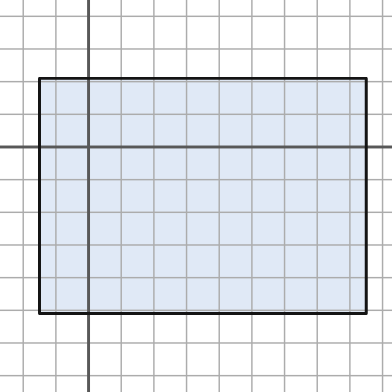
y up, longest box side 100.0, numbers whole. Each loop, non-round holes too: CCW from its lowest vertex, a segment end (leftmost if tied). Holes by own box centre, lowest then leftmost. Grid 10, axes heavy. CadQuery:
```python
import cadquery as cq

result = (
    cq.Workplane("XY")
    .moveTo(-15.0, -51.0)
    .lineTo(85.0, -51.0)
    .lineTo(85.0, 21.0)
    .lineTo(-15.0, 21.0)
    .close()
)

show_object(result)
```